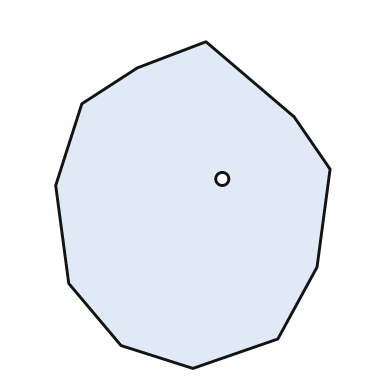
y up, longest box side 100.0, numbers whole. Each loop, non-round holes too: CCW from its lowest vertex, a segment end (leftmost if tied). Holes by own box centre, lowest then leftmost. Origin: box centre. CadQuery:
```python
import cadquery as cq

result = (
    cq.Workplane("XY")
    .moveTo(0.0, -50.0)
    .lineTo(26.0, -41.0)
    .lineTo(38.0, -19.0)
    .lineTo(42.0, 11.0)
    .lineTo(31.0, 27.0)
    .lineTo(4.0, 50.0)
    .lineTo(-17.0, 42.0)
    .lineTo(-34.0, 31.0)
    .lineTo(-42.0, 6.0)
    .lineTo(-38.0, -24.0)
    .lineTo(-22.0, -43.0)
    .close()
    .moveTo(9.0, 8.0)
    .circle(2.0)
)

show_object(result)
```